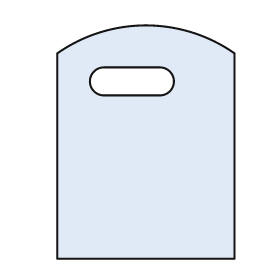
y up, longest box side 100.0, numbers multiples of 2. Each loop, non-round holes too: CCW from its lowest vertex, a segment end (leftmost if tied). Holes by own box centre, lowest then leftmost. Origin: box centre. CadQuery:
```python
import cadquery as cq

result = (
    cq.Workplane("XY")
    .moveTo(-38.0, -50.0)
    .lineTo(38.0, -50.0)
    .lineTo(38.0, 38.0)
    .threePointArc((0.0, 50.0), (-38.0, 38.0))
    .close()
    .moveTo(-18.0, 20.0)
    .lineTo(6.0, 20.0)
    .threePointArc((12.0, 26.0), (6.0, 32.0))
    .lineTo(-18.0, 32.0)
    .threePointArc((-24.0, 26.0), (-18.0, 20.0))
    .close()
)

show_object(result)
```